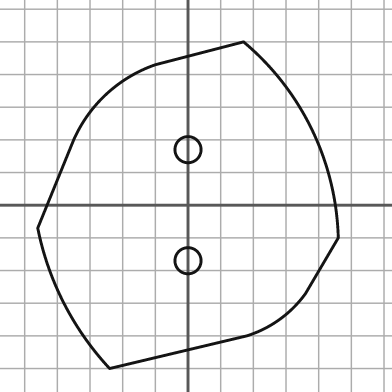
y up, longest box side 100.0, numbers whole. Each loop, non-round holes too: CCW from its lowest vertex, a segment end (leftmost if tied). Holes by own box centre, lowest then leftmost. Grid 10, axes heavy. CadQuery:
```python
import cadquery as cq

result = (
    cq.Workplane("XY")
    .moveTo(-24.0, -50.0)
    .lineTo(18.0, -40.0)
    .threePointArc((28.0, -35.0), (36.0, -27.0))
    .lineTo(46.0, -10.0)
    .threePointArc((38.0, 23.0), (17.0, 50.0))
    .lineTo(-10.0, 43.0)
    .threePointArc((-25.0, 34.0), (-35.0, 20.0))
    .lineTo(-46.0, -7.0)
    .threePointArc((-38.0, -30.0), (-24.0, -50.0))
    .close()
    .moveTo(0.0, -17.0)
    .circle(4.0)
    .moveTo(0.0, 17.0)
    .circle(4.0)
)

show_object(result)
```